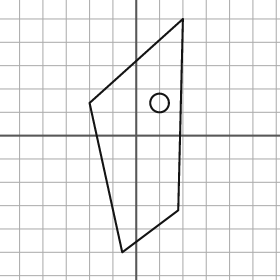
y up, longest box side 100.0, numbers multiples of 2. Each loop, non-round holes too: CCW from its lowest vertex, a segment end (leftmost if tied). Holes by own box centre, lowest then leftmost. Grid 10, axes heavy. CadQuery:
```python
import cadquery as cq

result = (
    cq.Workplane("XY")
    .moveTo(-6.0, -50.0)
    .lineTo(18.0, -32.0)
    .lineTo(20.0, 50.0)
    .lineTo(-20.0, 14.0)
    .close()
    .moveTo(10.0, 14.0)
    .circle(4.0)
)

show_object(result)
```